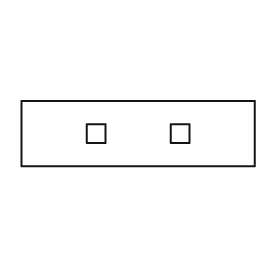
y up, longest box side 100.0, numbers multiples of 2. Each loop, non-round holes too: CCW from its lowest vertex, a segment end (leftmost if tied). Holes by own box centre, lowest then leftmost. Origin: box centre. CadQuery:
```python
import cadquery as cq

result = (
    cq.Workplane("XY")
    .moveTo(-50.0, -14.0)
    .lineTo(50.0, -14.0)
    .lineTo(50.0, 14.0)
    .lineTo(-50.0, 14.0)
    .close()
    .moveTo(-22.0, -4.0)
    .lineTo(-14.0, -4.0)
    .lineTo(-14.0, 4.0)
    .lineTo(-22.0, 4.0)
    .close()
    .moveTo(14.0, -4.0)
    .lineTo(22.0, -4.0)
    .lineTo(22.0, 4.0)
    .lineTo(14.0, 4.0)
    .close()
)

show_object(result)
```